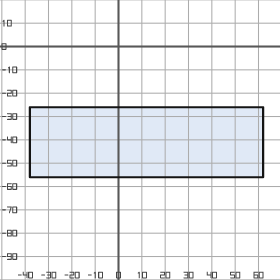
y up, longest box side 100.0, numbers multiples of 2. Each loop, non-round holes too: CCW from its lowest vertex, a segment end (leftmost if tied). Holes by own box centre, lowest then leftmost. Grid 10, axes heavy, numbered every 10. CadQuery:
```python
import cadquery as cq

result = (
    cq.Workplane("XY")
    .moveTo(-38.0, -56.0)
    .lineTo(62.0, -56.0)
    .lineTo(62.0, -26.0)
    .lineTo(-38.0, -26.0)
    .close()
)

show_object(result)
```